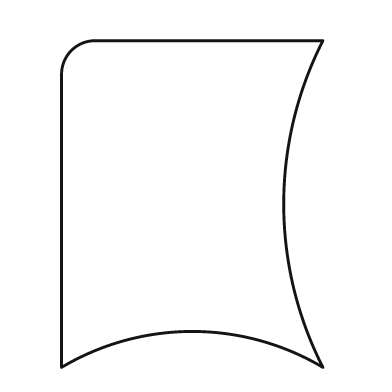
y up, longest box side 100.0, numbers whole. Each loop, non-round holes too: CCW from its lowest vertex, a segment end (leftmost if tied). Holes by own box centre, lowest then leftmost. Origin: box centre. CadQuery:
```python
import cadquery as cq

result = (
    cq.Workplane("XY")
    .moveTo(-40.0, -50.0)
    .threePointArc((0.0, -39.0), (40.0, -50.0))
    .threePointArc((28.0, 0.0), (40.0, 50.0))
    .lineTo(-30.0, 50.0)
    .threePointArc((-37.0, 47.0), (-40.0, 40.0))
    .close()
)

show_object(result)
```